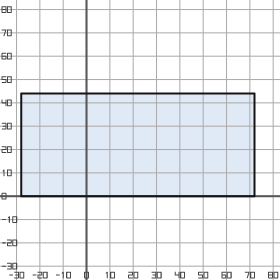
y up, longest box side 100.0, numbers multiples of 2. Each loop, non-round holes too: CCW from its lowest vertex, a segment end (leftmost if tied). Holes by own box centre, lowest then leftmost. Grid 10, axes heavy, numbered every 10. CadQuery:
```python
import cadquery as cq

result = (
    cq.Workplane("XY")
    .moveTo(-28.0, 0.0)
    .lineTo(72.0, 0.0)
    .lineTo(72.0, 44.0)
    .lineTo(-28.0, 44.0)
    .close()
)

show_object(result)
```